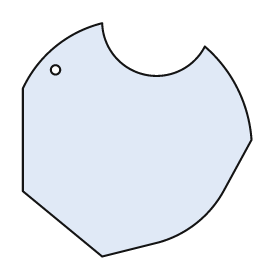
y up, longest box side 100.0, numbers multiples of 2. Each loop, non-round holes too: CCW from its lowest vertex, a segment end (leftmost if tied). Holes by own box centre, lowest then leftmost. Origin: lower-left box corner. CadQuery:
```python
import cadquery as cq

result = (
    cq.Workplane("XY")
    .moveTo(34.0, 0.0)
    .lineTo(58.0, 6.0)
    .threePointArc((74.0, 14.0), (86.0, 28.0))
    .lineTo(98.0, 50.0)
    .threePointArc((92.0, 72.0), (78.0, 90.0))
    .threePointArc((52.0, 78.0), (34.0, 100.0))
    .threePointArc((14.0, 90.0), (0.0, 72.0))
    .lineTo(0.0, 28.0)
    .close()
    .moveTo(14.0, 80.0)
    .circle(2.0)
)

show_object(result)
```